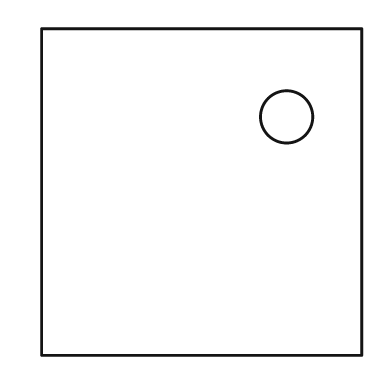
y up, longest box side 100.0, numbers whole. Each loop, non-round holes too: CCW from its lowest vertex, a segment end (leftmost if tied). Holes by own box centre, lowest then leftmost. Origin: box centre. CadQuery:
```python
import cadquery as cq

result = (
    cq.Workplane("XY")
    .moveTo(-49.0, -50.0)
    .lineTo(49.0, -50.0)
    .lineTo(49.0, 50.0)
    .lineTo(-49.0, 50.0)
    .close()
    .moveTo(26.0, 23.0)
    .circle(8.0)
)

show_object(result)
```